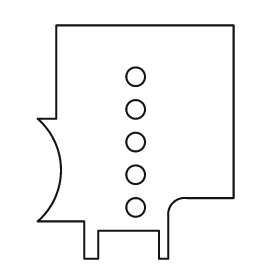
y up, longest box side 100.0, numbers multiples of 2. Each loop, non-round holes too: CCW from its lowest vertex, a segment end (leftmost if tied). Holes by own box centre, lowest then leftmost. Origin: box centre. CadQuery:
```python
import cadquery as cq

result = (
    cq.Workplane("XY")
    .moveTo(-22.0, -50.0)
    .lineTo(-16.0, -50.0)
    .lineTo(-16.0, -38.0)
    .lineTo(10.0, -38.0)
    .lineTo(10.0, -50.0)
    .lineTo(14.0, -50.0)
    .lineTo(14.0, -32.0)
    .threePointArc((16.0, -26.0), (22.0, -24.0))
    .lineTo(42.0, -24.0)
    .lineTo(42.0, 50.0)
    .lineTo(-34.0, 50.0)
    .lineTo(-34.0, 10.0)
    .lineTo(-42.0, 10.0)
    .threePointArc((-32.0, -12.0), (-42.0, -34.0))
    .lineTo(-22.0, -34.0)
    .close()
    .moveTo(0.0, -28.0)
    .circle(4.0)
    .moveTo(0.0, -14.0)
    .circle(4.0)
    .moveTo(0.0, 0.0)
    .circle(4.0)
    .moveTo(0.0, 14.0)
    .circle(4.0)
    .moveTo(0.0, 28.0)
    .circle(4.0)
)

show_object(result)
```